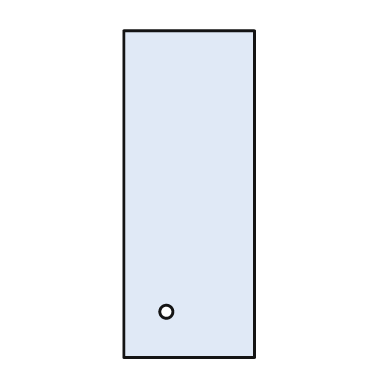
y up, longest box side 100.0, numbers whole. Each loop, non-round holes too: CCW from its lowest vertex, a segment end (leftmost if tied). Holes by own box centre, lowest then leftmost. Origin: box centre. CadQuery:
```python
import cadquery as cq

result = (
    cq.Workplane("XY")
    .moveTo(-20.0, -50.0)
    .lineTo(20.0, -50.0)
    .lineTo(20.0, 50.0)
    .lineTo(-20.0, 50.0)
    .close()
    .moveTo(-7.0, -36.0)
    .circle(2.0)
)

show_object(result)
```